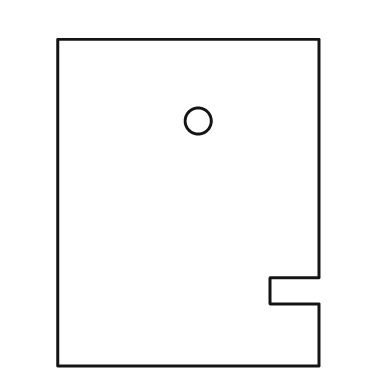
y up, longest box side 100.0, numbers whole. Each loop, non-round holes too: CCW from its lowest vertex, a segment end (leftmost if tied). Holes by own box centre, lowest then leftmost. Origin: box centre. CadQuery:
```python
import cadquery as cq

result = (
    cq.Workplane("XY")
    .moveTo(-40.0, -50.0)
    .lineTo(40.0, -50.0)
    .lineTo(40.0, -31.0)
    .lineTo(25.0, -31.0)
    .lineTo(25.0, -23.0)
    .lineTo(40.0, -23.0)
    .lineTo(40.0, 50.0)
    .lineTo(-40.0, 50.0)
    .close()
    .moveTo(3.0, 25.0)
    .circle(4.0)
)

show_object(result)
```